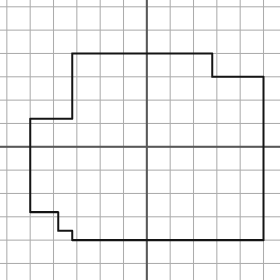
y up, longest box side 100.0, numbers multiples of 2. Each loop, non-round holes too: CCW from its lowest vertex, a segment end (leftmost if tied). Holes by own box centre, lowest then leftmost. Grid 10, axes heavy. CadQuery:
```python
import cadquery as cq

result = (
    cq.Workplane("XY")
    .moveTo(-32.0, -40.0)
    .lineTo(50.0, -40.0)
    .lineTo(50.0, 30.0)
    .lineTo(28.0, 30.0)
    .lineTo(28.0, 40.0)
    .lineTo(-32.0, 40.0)
    .lineTo(-32.0, 12.0)
    .lineTo(-50.0, 12.0)
    .lineTo(-50.0, -28.0)
    .lineTo(-38.0, -28.0)
    .lineTo(-38.0, -36.0)
    .lineTo(-32.0, -36.0)
    .close()
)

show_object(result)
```